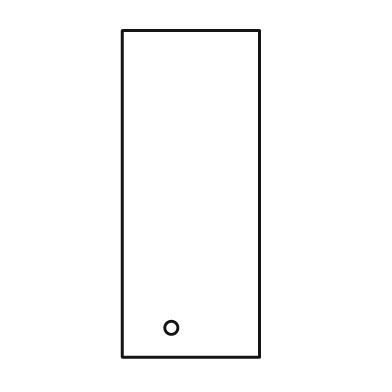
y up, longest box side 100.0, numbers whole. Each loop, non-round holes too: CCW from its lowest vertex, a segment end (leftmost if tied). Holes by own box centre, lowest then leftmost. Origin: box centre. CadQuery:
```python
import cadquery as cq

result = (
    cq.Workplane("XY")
    .moveTo(-21.0, -50.0)
    .lineTo(21.0, -50.0)
    .lineTo(21.0, 50.0)
    .lineTo(-21.0, 50.0)
    .close()
    .moveTo(-6.0, -41.0)
    .circle(2.0)
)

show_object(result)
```